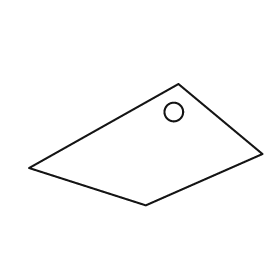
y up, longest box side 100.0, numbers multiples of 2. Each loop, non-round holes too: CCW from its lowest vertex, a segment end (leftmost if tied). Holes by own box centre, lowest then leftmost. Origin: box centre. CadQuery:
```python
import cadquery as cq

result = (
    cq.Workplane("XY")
    .moveTo(0.0, -26.0)
    .lineTo(50.0, -4.0)
    .lineTo(14.0, 26.0)
    .lineTo(-50.0, -10.0)
    .close()
    .moveTo(12.0, 14.0)
    .circle(4.0)
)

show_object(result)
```